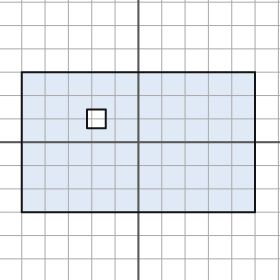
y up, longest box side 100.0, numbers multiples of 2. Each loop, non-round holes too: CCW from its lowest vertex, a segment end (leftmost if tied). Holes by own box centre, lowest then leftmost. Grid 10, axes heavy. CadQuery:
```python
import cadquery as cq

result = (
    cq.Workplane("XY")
    .moveTo(-50.0, -30.0)
    .lineTo(50.0, -30.0)
    .lineTo(50.0, 30.0)
    .lineTo(-50.0, 30.0)
    .close()
    .moveTo(-22.0, 6.0)
    .lineTo(-14.0, 6.0)
    .lineTo(-14.0, 14.0)
    .lineTo(-22.0, 14.0)
    .close()
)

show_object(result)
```